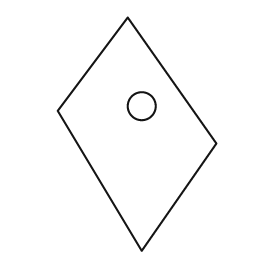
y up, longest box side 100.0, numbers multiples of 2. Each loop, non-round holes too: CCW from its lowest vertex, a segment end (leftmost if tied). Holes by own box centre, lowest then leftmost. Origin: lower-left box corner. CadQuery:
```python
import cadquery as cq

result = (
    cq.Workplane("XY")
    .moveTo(36.0, 0.0)
    .lineTo(68.0, 46.0)
    .lineTo(30.0, 100.0)
    .lineTo(0.0, 60.0)
    .close()
    .moveTo(36.0, 62.0)
    .circle(6.0)
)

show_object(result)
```